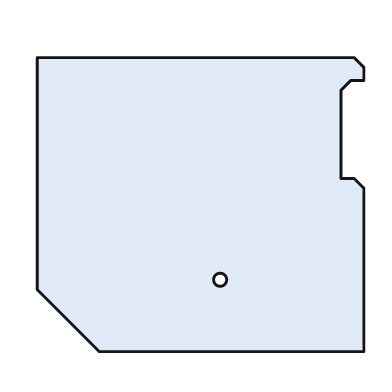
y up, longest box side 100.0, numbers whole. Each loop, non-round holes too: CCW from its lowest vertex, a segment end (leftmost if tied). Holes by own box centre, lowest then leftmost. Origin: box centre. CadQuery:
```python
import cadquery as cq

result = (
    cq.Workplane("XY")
    .moveTo(-31.0, -45.0)
    .lineTo(50.0, -45.0)
    .lineTo(50.0, 5.0)
    .lineTo(47.0, 8.0)
    .lineTo(43.0, 8.0)
    .lineTo(43.0, 35.0)
    .lineTo(46.0, 38.0)
    .lineTo(50.0, 38.0)
    .lineTo(50.0, 42.0)
    .lineTo(47.0, 45.0)
    .lineTo(-50.0, 45.0)
    .lineTo(-50.0, -26.0)
    .close()
    .moveTo(6.0, -23.0)
    .circle(2.0)
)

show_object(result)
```